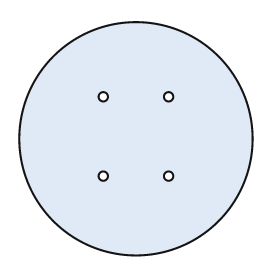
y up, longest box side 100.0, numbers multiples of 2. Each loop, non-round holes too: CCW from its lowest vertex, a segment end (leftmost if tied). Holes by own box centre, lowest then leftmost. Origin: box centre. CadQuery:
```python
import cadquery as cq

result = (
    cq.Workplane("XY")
    .moveTo(0.0, 0.0)
    .circle(50.0)
    .moveTo(-14.0, -16.0)
    .circle(2.0)
    .moveTo(14.0, -16.0)
    .circle(2.0)
    .moveTo(-14.0, 18.0)
    .circle(2.0)
    .moveTo(14.0, 18.0)
    .circle(2.0)
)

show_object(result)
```